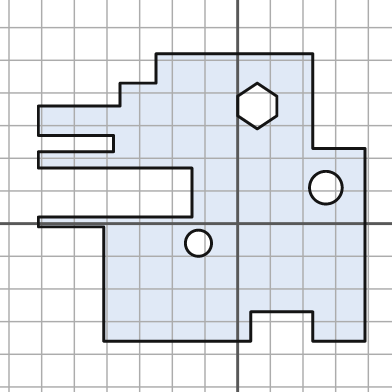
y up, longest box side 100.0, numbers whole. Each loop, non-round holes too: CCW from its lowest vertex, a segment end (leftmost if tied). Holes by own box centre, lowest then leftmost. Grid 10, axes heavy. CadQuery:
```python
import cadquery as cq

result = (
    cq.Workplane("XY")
    .moveTo(-41.0, -36.0)
    .lineTo(4.0, -36.0)
    .lineTo(4.0, -27.0)
    .lineTo(23.0, -27.0)
    .lineTo(23.0, -36.0)
    .lineTo(39.0, -36.0)
    .lineTo(39.0, 23.0)
    .lineTo(23.0, 23.0)
    .lineTo(23.0, 52.0)
    .lineTo(-25.0, 52.0)
    .lineTo(-25.0, 43.0)
    .lineTo(-36.0, 43.0)
    .lineTo(-36.0, 36.0)
    .lineTo(-61.0, 36.0)
    .lineTo(-61.0, 27.0)
    .lineTo(-38.0, 27.0)
    .lineTo(-38.0, 22.0)
    .lineTo(-61.0, 22.0)
    .lineTo(-61.0, 17.0)
    .lineTo(-14.0, 17.0)
    .lineTo(-14.0, 2.0)
    .lineTo(-61.0, 2.0)
    .lineTo(-61.0, -1.0)
    .lineTo(-41.0, -1.0)
    .close()
    .moveTo(-12.0, -6.0)
    .circle(4.0)
    .moveTo(27.0, 11.0)
    .circle(5.0)
    .moveTo(6.0, 29.0)
    .lineTo(12.0, 33.0)
    .lineTo(12.0, 39.0)
    .lineTo(6.0, 43.0)
    .lineTo(0.0, 39.0)
    .lineTo(0.0, 33.0)
    .close()
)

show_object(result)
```